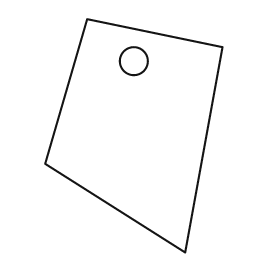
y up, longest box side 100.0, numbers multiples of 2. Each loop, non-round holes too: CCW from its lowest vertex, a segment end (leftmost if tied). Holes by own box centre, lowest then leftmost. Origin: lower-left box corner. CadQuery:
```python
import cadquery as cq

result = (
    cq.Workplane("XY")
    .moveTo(60.0, 0.0)
    .lineTo(76.0, 88.0)
    .lineTo(18.0, 100.0)
    .lineTo(0.0, 38.0)
    .close()
    .moveTo(38.0, 82.0)
    .circle(6.0)
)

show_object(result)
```